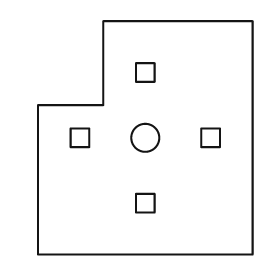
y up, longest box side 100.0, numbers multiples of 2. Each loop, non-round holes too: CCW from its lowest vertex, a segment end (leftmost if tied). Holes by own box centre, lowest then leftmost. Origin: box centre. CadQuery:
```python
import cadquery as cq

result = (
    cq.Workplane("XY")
    .moveTo(-46.0, -50.0)
    .lineTo(46.0, -50.0)
    .lineTo(46.0, 50.0)
    .lineTo(-18.0, 50.0)
    .lineTo(-18.0, 14.0)
    .lineTo(-46.0, 14.0)
    .close()
    .moveTo(-4.0, -32.0)
    .lineTo(4.0, -32.0)
    .lineTo(4.0, -24.0)
    .lineTo(-4.0, -24.0)
    .close()
    .moveTo(-32.0, -4.0)
    .lineTo(-24.0, -4.0)
    .lineTo(-24.0, 4.0)
    .lineTo(-32.0, 4.0)
    .close()
    .moveTo(0.0, 0.0)
    .circle(6.0)
    .moveTo(24.0, -4.0)
    .lineTo(32.0, -4.0)
    .lineTo(32.0, 4.0)
    .lineTo(24.0, 4.0)
    .close()
    .moveTo(-4.0, 24.0)
    .lineTo(4.0, 24.0)
    .lineTo(4.0, 32.0)
    .lineTo(-4.0, 32.0)
    .close()
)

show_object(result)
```